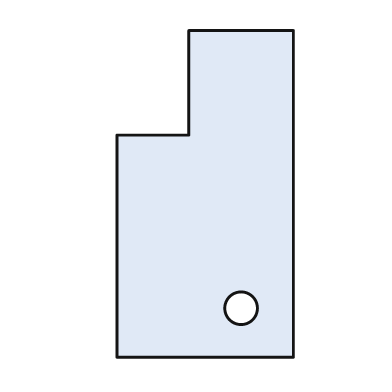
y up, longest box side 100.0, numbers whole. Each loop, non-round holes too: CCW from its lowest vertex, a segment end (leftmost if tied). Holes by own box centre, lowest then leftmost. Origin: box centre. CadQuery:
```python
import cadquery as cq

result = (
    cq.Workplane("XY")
    .moveTo(-27.0, -50.0)
    .lineTo(27.0, -50.0)
    .lineTo(27.0, 50.0)
    .lineTo(-5.0, 50.0)
    .lineTo(-5.0, 18.0)
    .lineTo(-27.0, 18.0)
    .close()
    .moveTo(11.0, -35.0)
    .circle(5.0)
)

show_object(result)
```